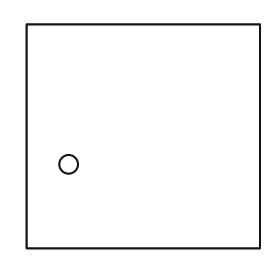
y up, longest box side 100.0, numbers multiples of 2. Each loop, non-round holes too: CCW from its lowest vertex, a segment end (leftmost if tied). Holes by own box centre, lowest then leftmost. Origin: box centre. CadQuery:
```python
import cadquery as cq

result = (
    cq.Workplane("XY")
    .moveTo(-50.0, -48.0)
    .lineTo(50.0, -48.0)
    .lineTo(50.0, 48.0)
    .lineTo(-50.0, 48.0)
    .close()
    .moveTo(-32.0, -12.0)
    .circle(4.0)
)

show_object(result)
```